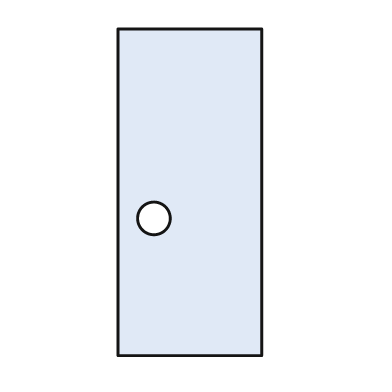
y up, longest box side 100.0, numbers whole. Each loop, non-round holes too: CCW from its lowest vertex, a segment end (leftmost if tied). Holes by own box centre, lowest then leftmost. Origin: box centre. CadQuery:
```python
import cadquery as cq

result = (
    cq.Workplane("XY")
    .moveTo(-22.0, -50.0)
    .lineTo(22.0, -50.0)
    .lineTo(22.0, 50.0)
    .lineTo(-22.0, 50.0)
    .close()
    .moveTo(-11.0, -8.0)
    .circle(5.0)
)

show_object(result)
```